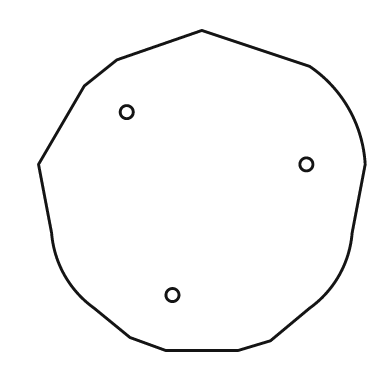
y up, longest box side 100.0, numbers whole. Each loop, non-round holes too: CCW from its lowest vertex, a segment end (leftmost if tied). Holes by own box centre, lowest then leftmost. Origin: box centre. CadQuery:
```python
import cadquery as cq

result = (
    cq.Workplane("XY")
    .moveTo(-11.0, -49.0)
    .lineTo(11.0, -49.0)
    .lineTo(21.0, -46.0)
    .lineTo(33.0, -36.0)
    .threePointArc((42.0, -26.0), (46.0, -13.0))
    .lineTo(50.0, 8.0)
    .threePointArc((45.0, 25.0), (33.0, 38.0))
    .lineTo(0.0, 49.0)
    .lineTo(-26.0, 40.0)
    .lineTo(-36.0, 32.0)
    .lineTo(-50.0, 8.0)
    .lineTo(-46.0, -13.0)
    .threePointArc((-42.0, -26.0), (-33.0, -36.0))
    .lineTo(-22.0, -45.0)
    .close()
    .moveTo(-9.0, -32.0)
    .circle(2.0)
    .moveTo(32.0, 8.0)
    .circle(2.0)
    .moveTo(-23.0, 24.0)
    .circle(2.0)
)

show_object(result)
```